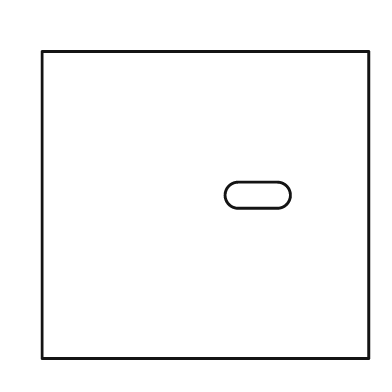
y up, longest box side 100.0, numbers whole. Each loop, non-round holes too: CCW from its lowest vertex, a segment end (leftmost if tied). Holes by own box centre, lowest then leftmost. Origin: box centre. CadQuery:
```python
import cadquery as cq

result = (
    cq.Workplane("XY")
    .moveTo(-50.0, -47.0)
    .lineTo(50.0, -47.0)
    .lineTo(50.0, 47.0)
    .lineTo(-50.0, 47.0)
    .close()
    .moveTo(10.0, -1.0)
    .lineTo(22.0, -1.0)
    .threePointArc((26.0, 3.0), (22.0, 7.0))
    .lineTo(10.0, 7.0)
    .threePointArc((6.0, 3.0), (10.0, -1.0))
    .close()
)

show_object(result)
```